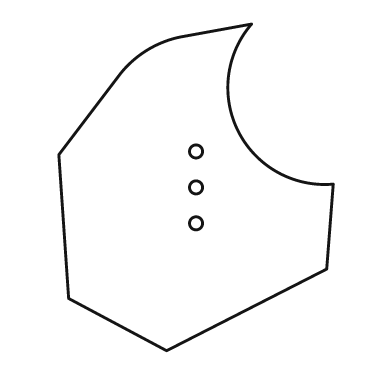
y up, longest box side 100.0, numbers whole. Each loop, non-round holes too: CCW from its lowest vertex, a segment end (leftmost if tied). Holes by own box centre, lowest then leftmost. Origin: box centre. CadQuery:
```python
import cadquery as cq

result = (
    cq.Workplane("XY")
    .moveTo(-9.0, -50.0)
    .lineTo(40.0, -25.0)
    .lineTo(42.0, 1.0)
    .threePointArc((13.0, 17.0), (17.0, 50.0))
    .lineTo(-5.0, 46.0)
    .threePointArc((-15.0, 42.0), (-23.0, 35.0))
    .lineTo(-42.0, 10.0)
    .lineTo(-39.0, -34.0)
    .close()
    .moveTo(0.0, -11.0)
    .circle(2.0)
    .moveTo(0.0, 0.0)
    .circle(2.0)
    .moveTo(0.0, 11.0)
    .circle(2.0)
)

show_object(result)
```